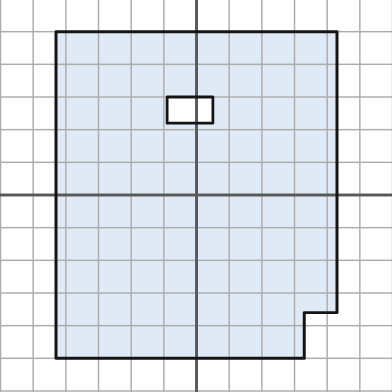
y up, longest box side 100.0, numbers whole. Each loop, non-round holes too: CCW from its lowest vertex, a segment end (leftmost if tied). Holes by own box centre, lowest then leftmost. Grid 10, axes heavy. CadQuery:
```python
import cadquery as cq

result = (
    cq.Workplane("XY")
    .moveTo(-43.0, -50.0)
    .lineTo(33.0, -50.0)
    .lineTo(33.0, -36.0)
    .lineTo(43.0, -36.0)
    .lineTo(43.0, 50.0)
    .lineTo(-43.0, 50.0)
    .close()
    .moveTo(-9.0, 22.0)
    .lineTo(5.0, 22.0)
    .lineTo(5.0, 30.0)
    .lineTo(-9.0, 30.0)
    .close()
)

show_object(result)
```